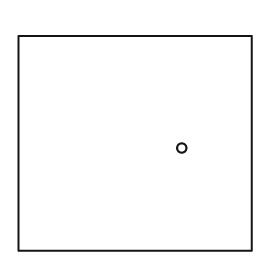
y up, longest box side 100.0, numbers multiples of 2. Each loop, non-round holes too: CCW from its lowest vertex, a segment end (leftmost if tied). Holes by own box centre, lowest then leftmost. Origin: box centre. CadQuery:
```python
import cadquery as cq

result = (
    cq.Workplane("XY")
    .moveTo(-50.0, -46.0)
    .lineTo(50.0, -46.0)
    .lineTo(50.0, 46.0)
    .lineTo(-50.0, 46.0)
    .close()
    .moveTo(20.0, -2.0)
    .circle(2.0)
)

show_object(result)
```